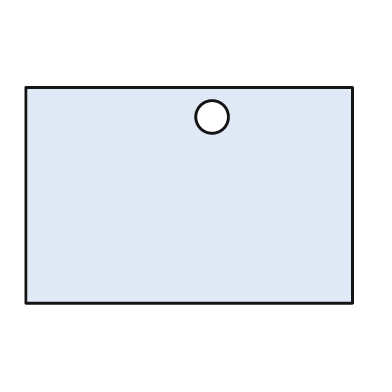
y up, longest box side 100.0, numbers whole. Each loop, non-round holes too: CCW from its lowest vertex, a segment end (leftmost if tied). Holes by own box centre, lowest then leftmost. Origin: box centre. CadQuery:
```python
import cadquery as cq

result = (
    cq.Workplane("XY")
    .moveTo(-50.0, -33.0)
    .lineTo(50.0, -33.0)
    .lineTo(50.0, 33.0)
    .lineTo(-50.0, 33.0)
    .close()
    .moveTo(7.0, 24.0)
    .circle(5.0)
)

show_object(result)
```